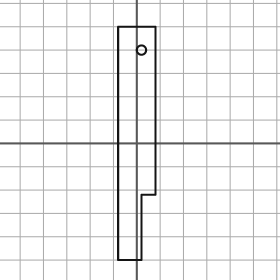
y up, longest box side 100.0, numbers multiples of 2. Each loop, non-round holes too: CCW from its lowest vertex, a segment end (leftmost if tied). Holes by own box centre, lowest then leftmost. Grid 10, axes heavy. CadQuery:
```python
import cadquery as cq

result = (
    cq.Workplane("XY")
    .moveTo(-8.0, -50.0)
    .lineTo(2.0, -50.0)
    .lineTo(2.0, -22.0)
    .lineTo(8.0, -22.0)
    .lineTo(8.0, 50.0)
    .lineTo(-8.0, 50.0)
    .close()
    .moveTo(2.0, 40.0)
    .circle(2.0)
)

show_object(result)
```